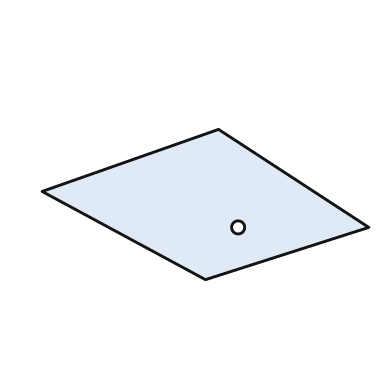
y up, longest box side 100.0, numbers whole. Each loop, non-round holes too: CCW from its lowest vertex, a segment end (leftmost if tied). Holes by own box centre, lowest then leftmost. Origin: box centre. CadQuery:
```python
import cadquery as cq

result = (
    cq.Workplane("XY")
    .moveTo(0.0, -23.0)
    .lineTo(50.0, -7.0)
    .lineTo(4.0, 23.0)
    .lineTo(-50.0, 4.0)
    .close()
    .moveTo(10.0, -7.0)
    .circle(2.0)
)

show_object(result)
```